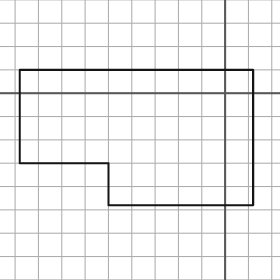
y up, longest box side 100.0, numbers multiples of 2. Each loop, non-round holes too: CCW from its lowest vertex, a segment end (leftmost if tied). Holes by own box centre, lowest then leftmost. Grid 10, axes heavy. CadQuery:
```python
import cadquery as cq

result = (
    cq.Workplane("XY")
    .moveTo(-50.0, -48.0)
    .lineTo(12.0, -48.0)
    .lineTo(12.0, 10.0)
    .lineTo(-88.0, 10.0)
    .lineTo(-88.0, -30.0)
    .lineTo(-50.0, -30.0)
    .close()
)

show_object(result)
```